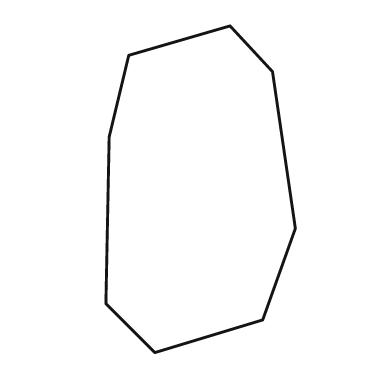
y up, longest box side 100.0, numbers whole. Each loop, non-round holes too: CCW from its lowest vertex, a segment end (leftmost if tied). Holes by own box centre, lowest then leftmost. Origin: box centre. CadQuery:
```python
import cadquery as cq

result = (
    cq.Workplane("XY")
    .moveTo(-14.0, -50.0)
    .lineTo(19.0, -40.0)
    .lineTo(29.0, -12.0)
    .lineTo(22.0, 36.0)
    .lineTo(9.0, 50.0)
    .lineTo(-22.0, 41.0)
    .lineTo(-28.0, 16.0)
    .lineTo(-29.0, -35.0)
    .close()
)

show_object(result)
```